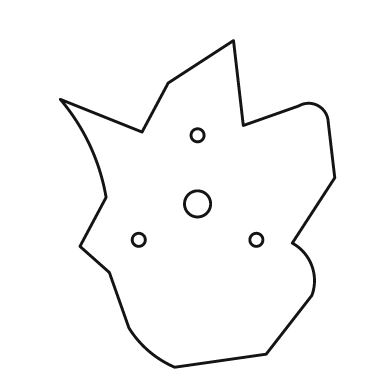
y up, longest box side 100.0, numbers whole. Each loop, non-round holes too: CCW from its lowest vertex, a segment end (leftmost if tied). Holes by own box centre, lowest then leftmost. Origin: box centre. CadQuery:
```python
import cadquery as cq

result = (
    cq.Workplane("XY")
    .moveTo(-7.0, -50.0)
    .lineTo(21.0, -46.0)
    .lineTo(35.0, -28.0)
    .threePointArc((35.0, -19.0), (29.0, -12.0))
    .lineTo(42.0, 8.0)
    .lineTo(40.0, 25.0)
    .threePointArc((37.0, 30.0), (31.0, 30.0))
    .lineTo(14.0, 24.0)
    .lineTo(11.0, 50.0)
    .lineTo(-9.0, 37.0)
    .lineTo(-17.0, 22.0)
    .lineTo(-42.0, 32.0)
    .threePointArc((-33.0, 18.0), (-28.0, 2.0))
    .lineTo(-36.0, -13.0)
    .lineTo(-27.0, -21.0)
    .lineTo(-21.0, -38.0)
    .threePointArc((-15.0, -45.0), (-7.0, -50.0))
    .close()
    .moveTo(-18.0, -11.0)
    .circle(2.0)
    .moveTo(18.0, -11.0)
    .circle(2.0)
    .moveTo(0.0, 0.0)
    .circle(4.0)
    .moveTo(0.0, 21.0)
    .circle(2.0)
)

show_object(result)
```